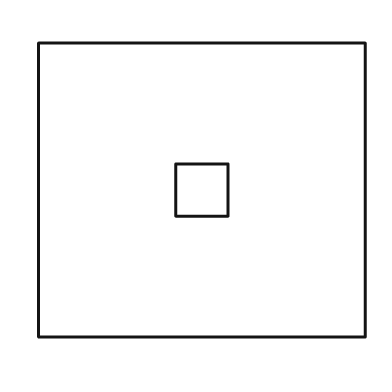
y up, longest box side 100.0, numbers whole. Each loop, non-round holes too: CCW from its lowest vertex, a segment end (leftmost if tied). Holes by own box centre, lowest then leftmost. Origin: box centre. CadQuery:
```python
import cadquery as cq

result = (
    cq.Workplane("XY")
    .moveTo(-50.0, -45.0)
    .lineTo(50.0, -45.0)
    .lineTo(50.0, 45.0)
    .lineTo(-50.0, 45.0)
    .close()
    .moveTo(-8.0, -8.0)
    .lineTo(8.0, -8.0)
    .lineTo(8.0, 8.0)
    .lineTo(-8.0, 8.0)
    .close()
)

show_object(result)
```